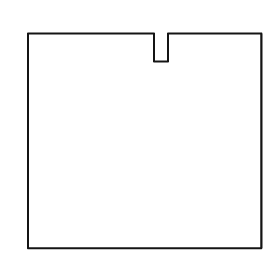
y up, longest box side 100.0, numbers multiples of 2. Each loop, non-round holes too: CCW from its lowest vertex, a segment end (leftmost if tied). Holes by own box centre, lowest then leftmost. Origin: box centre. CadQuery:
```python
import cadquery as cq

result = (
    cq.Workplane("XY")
    .moveTo(-50.0, -46.0)
    .lineTo(50.0, -46.0)
    .lineTo(50.0, 46.0)
    .lineTo(10.0, 46.0)
    .lineTo(10.0, 34.0)
    .lineTo(4.0, 34.0)
    .lineTo(4.0, 46.0)
    .lineTo(-50.0, 46.0)
    .close()
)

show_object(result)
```